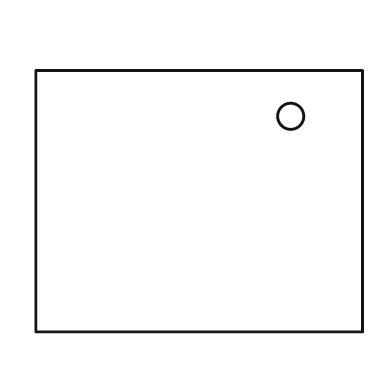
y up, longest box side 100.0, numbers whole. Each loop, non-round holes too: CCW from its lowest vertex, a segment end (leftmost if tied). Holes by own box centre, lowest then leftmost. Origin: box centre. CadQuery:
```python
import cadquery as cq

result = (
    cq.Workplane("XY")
    .moveTo(-50.0, -40.0)
    .lineTo(50.0, -40.0)
    .lineTo(50.0, 40.0)
    .lineTo(-50.0, 40.0)
    .close()
    .moveTo(28.0, 26.0)
    .circle(4.0)
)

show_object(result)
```